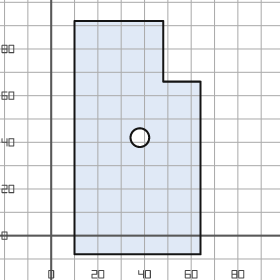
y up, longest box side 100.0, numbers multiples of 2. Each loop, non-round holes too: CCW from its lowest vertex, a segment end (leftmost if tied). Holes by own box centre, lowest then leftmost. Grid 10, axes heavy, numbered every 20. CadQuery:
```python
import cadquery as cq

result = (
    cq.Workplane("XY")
    .moveTo(10.0, -8.0)
    .lineTo(64.0, -8.0)
    .lineTo(64.0, 66.0)
    .lineTo(48.0, 66.0)
    .lineTo(48.0, 92.0)
    .lineTo(10.0, 92.0)
    .close()
    .moveTo(38.0, 42.0)
    .circle(4.0)
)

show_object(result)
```